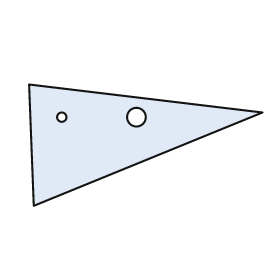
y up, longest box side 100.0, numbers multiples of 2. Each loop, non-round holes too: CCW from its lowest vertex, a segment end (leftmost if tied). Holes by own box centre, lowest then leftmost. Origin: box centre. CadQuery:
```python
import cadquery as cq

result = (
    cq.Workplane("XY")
    .moveTo(-48.0, -26.0)
    .lineTo(50.0, 14.0)
    .lineTo(-50.0, 26.0)
    .close()
    .moveTo(-36.0, 12.0)
    .circle(2.0)
    .moveTo(-4.0, 12.0)
    .circle(4.0)
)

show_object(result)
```